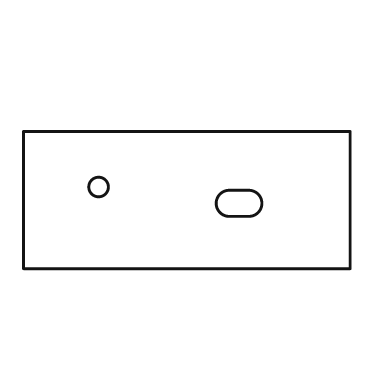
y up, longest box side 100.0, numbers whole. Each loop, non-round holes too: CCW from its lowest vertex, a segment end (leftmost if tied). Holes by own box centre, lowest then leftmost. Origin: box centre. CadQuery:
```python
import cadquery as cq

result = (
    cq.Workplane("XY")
    .moveTo(-50.0, -21.0)
    .lineTo(50.0, -21.0)
    .lineTo(50.0, 21.0)
    .lineTo(-50.0, 21.0)
    .close()
    .moveTo(13.0, -5.0)
    .lineTo(19.0, -5.0)
    .threePointArc((23.0, -1.0), (19.0, 3.0))
    .lineTo(13.0, 3.0)
    .threePointArc((9.0, -1.0), (13.0, -5.0))
    .close()
    .moveTo(-27.0, 4.0)
    .circle(3.0)
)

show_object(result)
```